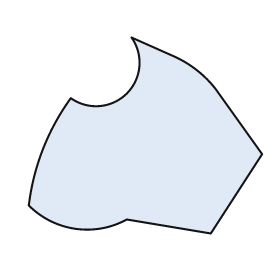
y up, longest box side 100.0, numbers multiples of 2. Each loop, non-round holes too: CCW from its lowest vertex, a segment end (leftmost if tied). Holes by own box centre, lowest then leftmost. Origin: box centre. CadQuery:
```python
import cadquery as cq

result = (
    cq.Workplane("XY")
    .moveTo(28.0, -42.0)
    .lineTo(50.0, -8.0)
    .lineTo(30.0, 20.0)
    .threePointArc((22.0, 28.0), (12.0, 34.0))
    .lineTo(-6.0, 42.0)
    .threePointArc((-8.0, 18.0), (-32.0, 16.0))
    .threePointArc((-44.0, -6.0), (-50.0, -30.0))
    .threePointArc((-30.0, -40.0), (-8.0, -36.0))
    .close()
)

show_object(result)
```